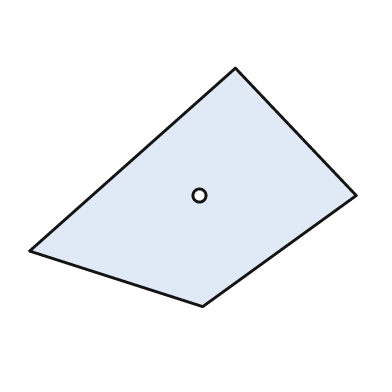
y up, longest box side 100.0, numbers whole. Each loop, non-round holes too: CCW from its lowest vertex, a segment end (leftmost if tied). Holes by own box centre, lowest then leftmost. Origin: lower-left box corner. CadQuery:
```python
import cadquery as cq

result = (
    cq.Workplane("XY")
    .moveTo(53.0, 0.0)
    .lineTo(100.0, 34.0)
    .lineTo(63.0, 73.0)
    .lineTo(0.0, 17.0)
    .close()
    .moveTo(52.0, 34.0)
    .circle(2.0)
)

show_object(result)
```